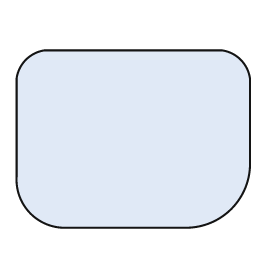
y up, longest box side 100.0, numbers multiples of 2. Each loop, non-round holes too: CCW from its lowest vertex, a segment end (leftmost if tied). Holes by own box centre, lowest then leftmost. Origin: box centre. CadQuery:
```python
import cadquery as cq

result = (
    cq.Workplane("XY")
    .moveTo(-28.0, -38.0)
    .lineTo(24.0, -38.0)
    .threePointArc((42.0, -30.0), (50.0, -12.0))
    .lineTo(50.0, 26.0)
    .threePointArc((46.0, 34.0), (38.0, 38.0))
    .lineTo(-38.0, 38.0)
    .threePointArc((-46.0, 34.0), (-50.0, 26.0))
    .lineTo(-50.0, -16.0)
    .threePointArc((-44.0, -32.0), (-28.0, -38.0))
    .close()
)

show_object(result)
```